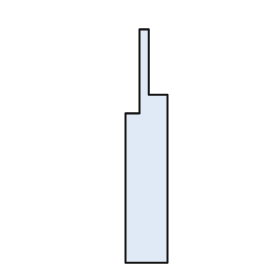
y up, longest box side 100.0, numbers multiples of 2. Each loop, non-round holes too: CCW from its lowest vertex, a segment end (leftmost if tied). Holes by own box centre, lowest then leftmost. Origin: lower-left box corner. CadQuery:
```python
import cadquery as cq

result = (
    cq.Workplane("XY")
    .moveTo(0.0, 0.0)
    .lineTo(18.0, 0.0)
    .lineTo(18.0, 72.0)
    .lineTo(10.0, 72.0)
    .lineTo(10.0, 100.0)
    .lineTo(6.0, 100.0)
    .lineTo(6.0, 64.0)
    .lineTo(0.0, 64.0)
    .close()
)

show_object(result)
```